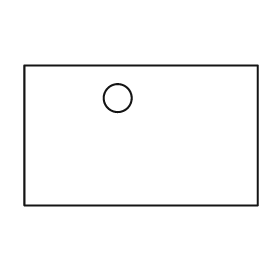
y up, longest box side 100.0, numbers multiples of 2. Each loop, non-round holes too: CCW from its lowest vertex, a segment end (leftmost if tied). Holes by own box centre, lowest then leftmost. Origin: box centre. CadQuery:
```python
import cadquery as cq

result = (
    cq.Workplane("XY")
    .moveTo(-50.0, -30.0)
    .lineTo(50.0, -30.0)
    .lineTo(50.0, 30.0)
    .lineTo(-50.0, 30.0)
    .close()
    .moveTo(-10.0, 16.0)
    .circle(6.0)
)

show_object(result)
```